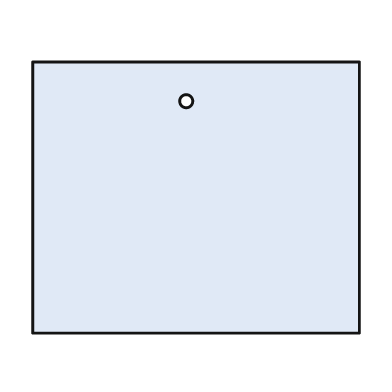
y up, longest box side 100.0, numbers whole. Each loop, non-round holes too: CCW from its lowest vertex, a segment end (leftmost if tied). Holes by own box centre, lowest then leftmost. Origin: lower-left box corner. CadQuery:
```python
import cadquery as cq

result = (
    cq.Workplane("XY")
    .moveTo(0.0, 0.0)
    .lineTo(100.0, 0.0)
    .lineTo(100.0, 83.0)
    .lineTo(0.0, 83.0)
    .close()
    .moveTo(47.0, 71.0)
    .circle(2.0)
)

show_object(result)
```